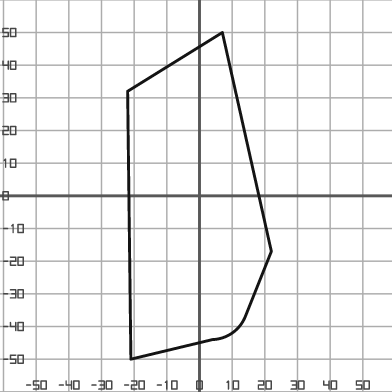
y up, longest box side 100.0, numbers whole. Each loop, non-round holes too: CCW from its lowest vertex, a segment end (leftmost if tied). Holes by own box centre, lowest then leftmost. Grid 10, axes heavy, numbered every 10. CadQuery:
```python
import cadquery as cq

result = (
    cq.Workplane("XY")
    .moveTo(-21.0, -50.0)
    .lineTo(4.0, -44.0)
    .threePointArc((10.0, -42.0), (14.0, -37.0))
    .lineTo(22.0, -17.0)
    .lineTo(7.0, 50.0)
    .lineTo(-22.0, 32.0)
    .close()
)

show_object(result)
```